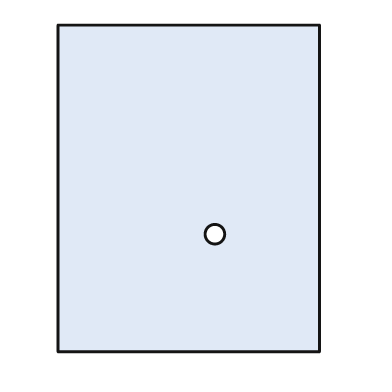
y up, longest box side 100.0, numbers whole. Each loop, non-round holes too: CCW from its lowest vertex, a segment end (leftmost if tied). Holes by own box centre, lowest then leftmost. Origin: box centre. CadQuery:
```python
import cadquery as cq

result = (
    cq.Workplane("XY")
    .moveTo(-40.0, -50.0)
    .lineTo(40.0, -50.0)
    .lineTo(40.0, 50.0)
    .lineTo(-40.0, 50.0)
    .close()
    .moveTo(8.0, -14.0)
    .circle(3.0)
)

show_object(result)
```